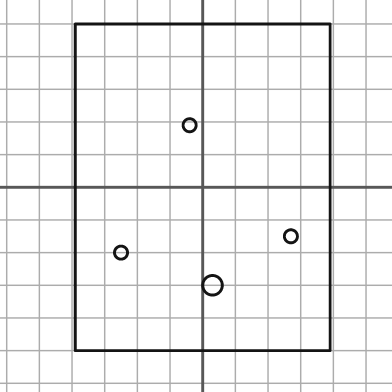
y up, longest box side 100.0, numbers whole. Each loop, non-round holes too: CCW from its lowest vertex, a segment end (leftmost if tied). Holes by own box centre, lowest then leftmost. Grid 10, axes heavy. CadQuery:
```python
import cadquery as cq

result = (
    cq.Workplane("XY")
    .moveTo(-39.0, -50.0)
    .lineTo(39.0, -50.0)
    .lineTo(39.0, 50.0)
    .lineTo(-39.0, 50.0)
    .close()
    .moveTo(3.0, -30.0)
    .circle(3.0)
    .moveTo(-25.0, -20.0)
    .circle(2.0)
    .moveTo(27.0, -15.0)
    .circle(2.0)
    .moveTo(-4.0, 19.0)
    .circle(2.0)
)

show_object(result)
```